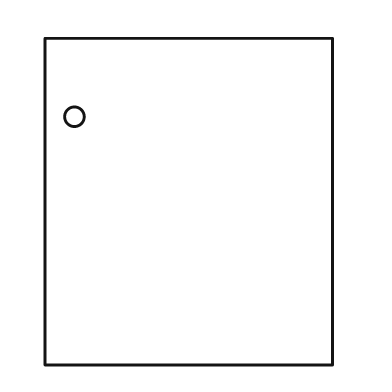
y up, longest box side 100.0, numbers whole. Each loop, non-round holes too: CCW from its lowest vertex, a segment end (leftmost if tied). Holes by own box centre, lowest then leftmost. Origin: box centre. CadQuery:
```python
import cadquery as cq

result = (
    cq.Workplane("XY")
    .moveTo(-44.0, -50.0)
    .lineTo(44.0, -50.0)
    .lineTo(44.0, 50.0)
    .lineTo(-44.0, 50.0)
    .close()
    .moveTo(-35.0, 26.0)
    .circle(3.0)
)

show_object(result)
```